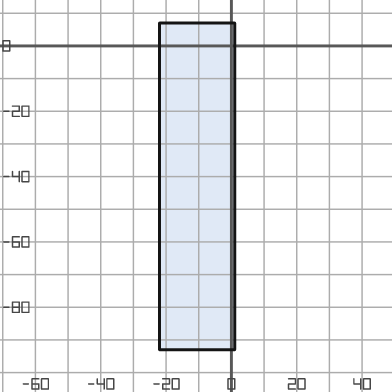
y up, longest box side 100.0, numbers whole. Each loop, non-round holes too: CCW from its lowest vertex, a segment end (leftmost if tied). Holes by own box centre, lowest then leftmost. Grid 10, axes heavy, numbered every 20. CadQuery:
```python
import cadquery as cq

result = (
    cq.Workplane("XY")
    .moveTo(-22.0, -93.0)
    .lineTo(1.0, -93.0)
    .lineTo(1.0, 7.0)
    .lineTo(-22.0, 7.0)
    .close()
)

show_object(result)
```